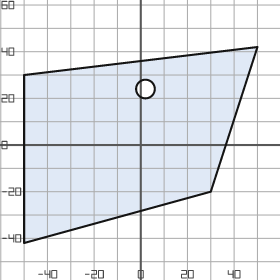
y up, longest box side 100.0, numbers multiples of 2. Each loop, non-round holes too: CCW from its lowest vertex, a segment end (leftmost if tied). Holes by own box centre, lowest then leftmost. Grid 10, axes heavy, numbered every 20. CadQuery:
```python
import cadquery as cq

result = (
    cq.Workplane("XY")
    .moveTo(-50.0, -42.0)
    .lineTo(30.0, -20.0)
    .lineTo(50.0, 42.0)
    .lineTo(-50.0, 30.0)
    .close()
    .moveTo(2.0, 24.0)
    .circle(4.0)
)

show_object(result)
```